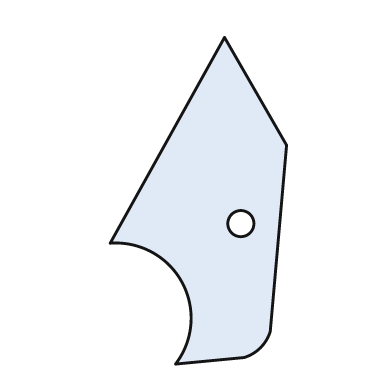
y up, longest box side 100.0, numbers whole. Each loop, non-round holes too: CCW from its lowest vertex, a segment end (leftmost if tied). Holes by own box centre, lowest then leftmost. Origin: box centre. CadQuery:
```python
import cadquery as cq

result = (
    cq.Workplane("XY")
    .moveTo(-7.0, -50.0)
    .lineTo(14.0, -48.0)
    .threePointArc((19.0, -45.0), (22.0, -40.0))
    .lineTo(27.0, 17.0)
    .lineTo(8.0, 50.0)
    .lineTo(-27.0, -13.0)
    .threePointArc((-5.0, -25.0), (-7.0, -50.0))
    .close()
    .moveTo(13.0, -7.0)
    .circle(4.0)
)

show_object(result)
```